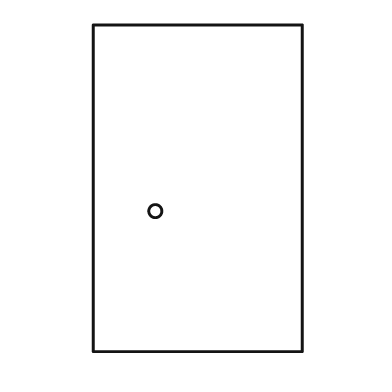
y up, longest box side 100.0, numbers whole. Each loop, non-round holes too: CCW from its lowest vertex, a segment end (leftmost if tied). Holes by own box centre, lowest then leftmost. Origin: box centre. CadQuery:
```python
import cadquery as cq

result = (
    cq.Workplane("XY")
    .moveTo(-32.0, -50.0)
    .lineTo(32.0, -50.0)
    .lineTo(32.0, 50.0)
    .lineTo(-32.0, 50.0)
    .close()
    .moveTo(-13.0, -7.0)
    .circle(2.0)
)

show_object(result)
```